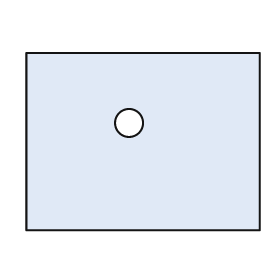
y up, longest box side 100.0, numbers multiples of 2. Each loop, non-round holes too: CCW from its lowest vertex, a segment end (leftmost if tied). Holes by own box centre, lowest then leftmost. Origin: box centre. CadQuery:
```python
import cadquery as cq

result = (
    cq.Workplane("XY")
    .moveTo(-50.0, -38.0)
    .lineTo(50.0, -38.0)
    .lineTo(50.0, 38.0)
    .lineTo(-50.0, 38.0)
    .close()
    .moveTo(-6.0, 8.0)
    .circle(6.0)
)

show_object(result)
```